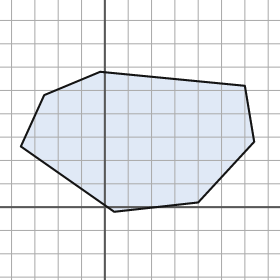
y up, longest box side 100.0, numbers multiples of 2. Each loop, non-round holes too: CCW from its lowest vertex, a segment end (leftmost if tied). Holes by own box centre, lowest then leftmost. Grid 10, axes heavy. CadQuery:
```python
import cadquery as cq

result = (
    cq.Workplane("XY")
    .moveTo(4.0, -2.0)
    .lineTo(40.0, 2.0)
    .lineTo(64.0, 28.0)
    .lineTo(60.0, 52.0)
    .lineTo(-2.0, 58.0)
    .lineTo(-26.0, 48.0)
    .lineTo(-36.0, 26.0)
    .close()
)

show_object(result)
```